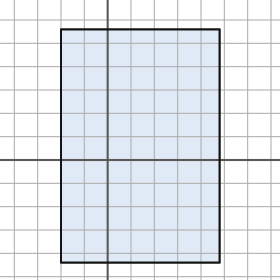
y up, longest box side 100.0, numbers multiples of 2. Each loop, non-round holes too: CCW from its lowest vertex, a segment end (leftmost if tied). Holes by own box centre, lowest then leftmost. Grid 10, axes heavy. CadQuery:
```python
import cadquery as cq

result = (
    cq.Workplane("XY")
    .moveTo(-20.0, -44.0)
    .lineTo(48.0, -44.0)
    .lineTo(48.0, 56.0)
    .lineTo(-20.0, 56.0)
    .close()
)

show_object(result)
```